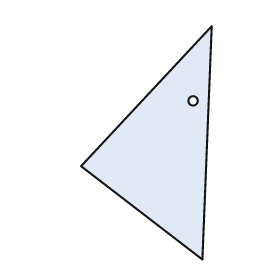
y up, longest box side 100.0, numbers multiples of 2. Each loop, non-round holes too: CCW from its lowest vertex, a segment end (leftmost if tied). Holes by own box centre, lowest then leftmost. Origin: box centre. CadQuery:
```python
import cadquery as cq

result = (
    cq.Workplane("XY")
    .moveTo(24.0, -50.0)
    .lineTo(28.0, 50.0)
    .lineTo(-28.0, -10.0)
    .close()
    .moveTo(20.0, 18.0)
    .circle(2.0)
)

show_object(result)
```